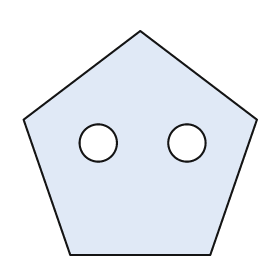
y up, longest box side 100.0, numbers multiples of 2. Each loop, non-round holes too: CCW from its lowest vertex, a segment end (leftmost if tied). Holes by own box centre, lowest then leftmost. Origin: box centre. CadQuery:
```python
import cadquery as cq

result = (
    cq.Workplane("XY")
    .moveTo(-30.0, -48.0)
    .lineTo(30.0, -48.0)
    .lineTo(50.0, 10.0)
    .lineTo(0.0, 48.0)
    .lineTo(-50.0, 10.0)
    .close()
    .moveTo(-18.0, 0.0)
    .circle(8.0)
    .moveTo(20.0, 0.0)
    .circle(8.0)
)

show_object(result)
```